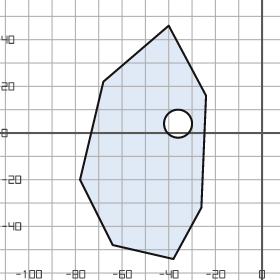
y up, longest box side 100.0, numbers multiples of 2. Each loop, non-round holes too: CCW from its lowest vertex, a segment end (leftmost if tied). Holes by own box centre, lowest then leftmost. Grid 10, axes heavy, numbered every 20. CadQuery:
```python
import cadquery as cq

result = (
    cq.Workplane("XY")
    .moveTo(-38.0, -54.0)
    .lineTo(-26.0, -32.0)
    .lineTo(-24.0, 16.0)
    .lineTo(-40.0, 46.0)
    .lineTo(-68.0, 22.0)
    .lineTo(-78.0, -20.0)
    .lineTo(-64.0, -48.0)
    .close()
    .moveTo(-36.0, 4.0)
    .circle(6.0)
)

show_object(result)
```